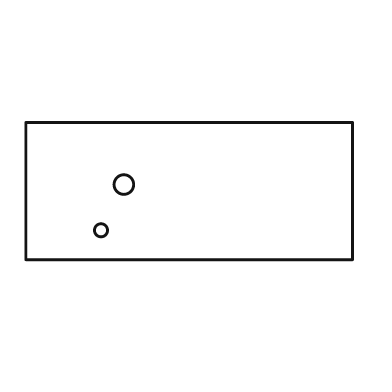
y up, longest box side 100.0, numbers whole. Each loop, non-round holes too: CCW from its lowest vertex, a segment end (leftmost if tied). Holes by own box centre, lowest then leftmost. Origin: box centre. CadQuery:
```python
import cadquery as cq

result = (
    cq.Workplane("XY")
    .moveTo(-50.0, -21.0)
    .lineTo(50.0, -21.0)
    .lineTo(50.0, 21.0)
    .lineTo(-50.0, 21.0)
    .close()
    .moveTo(-27.0, -12.0)
    .circle(2.0)
    .moveTo(-20.0, 2.0)
    .circle(3.0)
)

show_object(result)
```